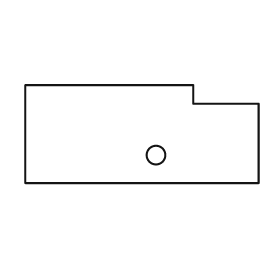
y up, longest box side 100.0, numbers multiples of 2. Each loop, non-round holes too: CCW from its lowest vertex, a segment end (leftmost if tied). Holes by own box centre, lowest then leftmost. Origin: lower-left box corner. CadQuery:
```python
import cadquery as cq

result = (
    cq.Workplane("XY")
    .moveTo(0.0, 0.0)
    .lineTo(100.0, 0.0)
    .lineTo(100.0, 34.0)
    .lineTo(72.0, 34.0)
    .lineTo(72.0, 42.0)
    .lineTo(0.0, 42.0)
    .close()
    .moveTo(56.0, 12.0)
    .circle(4.0)
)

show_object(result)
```